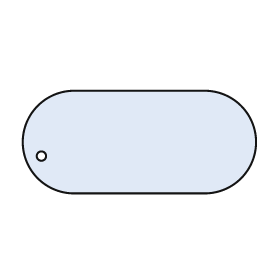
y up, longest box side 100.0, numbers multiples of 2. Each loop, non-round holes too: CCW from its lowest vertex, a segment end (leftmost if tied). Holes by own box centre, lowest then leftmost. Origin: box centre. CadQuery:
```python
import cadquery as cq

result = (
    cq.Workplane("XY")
    .moveTo(-28.0, -22.0)
    .lineTo(28.0, -22.0)
    .threePointArc((50.0, 0.0), (28.0, 22.0))
    .lineTo(-28.0, 22.0)
    .threePointArc((-50.0, 0.0), (-28.0, -22.0))
    .close()
    .moveTo(-42.0, -6.0)
    .circle(2.0)
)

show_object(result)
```